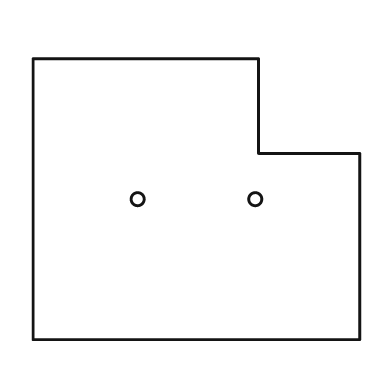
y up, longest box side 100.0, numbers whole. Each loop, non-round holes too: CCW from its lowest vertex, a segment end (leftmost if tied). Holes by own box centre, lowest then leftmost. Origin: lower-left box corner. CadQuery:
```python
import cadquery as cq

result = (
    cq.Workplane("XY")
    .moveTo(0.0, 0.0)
    .lineTo(100.0, 0.0)
    .lineTo(100.0, 57.0)
    .lineTo(69.0, 57.0)
    .lineTo(69.0, 86.0)
    .lineTo(0.0, 86.0)
    .close()
    .moveTo(32.0, 43.0)
    .circle(2.0)
    .moveTo(68.0, 43.0)
    .circle(2.0)
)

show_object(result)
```